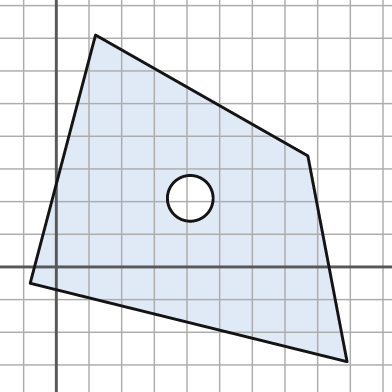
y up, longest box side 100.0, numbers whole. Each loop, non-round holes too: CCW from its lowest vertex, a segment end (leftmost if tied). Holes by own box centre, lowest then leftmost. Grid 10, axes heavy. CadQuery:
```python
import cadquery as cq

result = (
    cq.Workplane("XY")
    .moveTo(89.0, -29.0)
    .lineTo(77.0, 34.0)
    .lineTo(12.0, 71.0)
    .lineTo(-8.0, -5.0)
    .close()
    .moveTo(41.0, 21.0)
    .circle(7.0)
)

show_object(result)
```